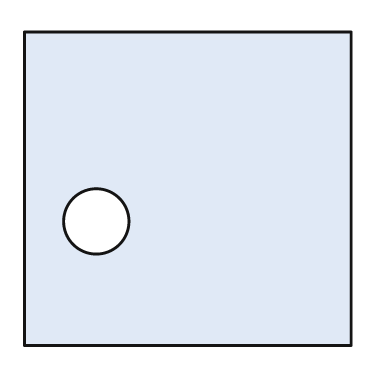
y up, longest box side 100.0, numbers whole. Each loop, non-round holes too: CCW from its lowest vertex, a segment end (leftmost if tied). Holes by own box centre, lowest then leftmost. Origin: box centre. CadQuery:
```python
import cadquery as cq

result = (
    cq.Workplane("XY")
    .moveTo(-50.0, -48.0)
    .lineTo(50.0, -48.0)
    .lineTo(50.0, 48.0)
    .lineTo(-50.0, 48.0)
    .close()
    .moveTo(-28.0, -10.0)
    .circle(10.0)
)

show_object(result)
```